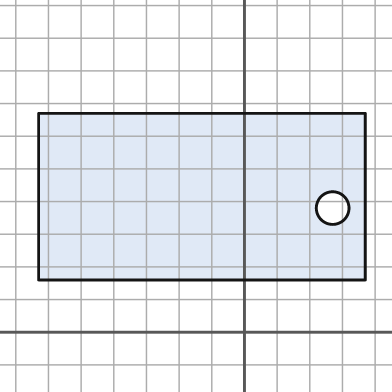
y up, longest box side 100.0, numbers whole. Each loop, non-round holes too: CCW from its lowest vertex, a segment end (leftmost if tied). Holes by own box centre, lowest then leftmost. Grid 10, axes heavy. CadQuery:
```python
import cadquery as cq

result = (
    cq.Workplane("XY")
    .moveTo(-63.0, 16.0)
    .lineTo(37.0, 16.0)
    .lineTo(37.0, 67.0)
    .lineTo(-63.0, 67.0)
    .close()
    .moveTo(27.0, 38.0)
    .circle(5.0)
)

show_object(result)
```